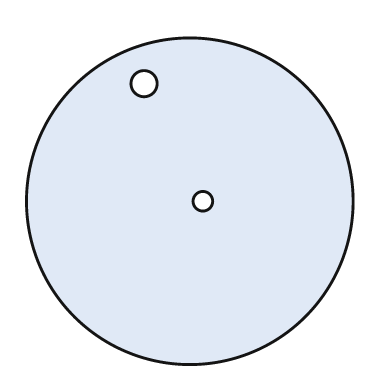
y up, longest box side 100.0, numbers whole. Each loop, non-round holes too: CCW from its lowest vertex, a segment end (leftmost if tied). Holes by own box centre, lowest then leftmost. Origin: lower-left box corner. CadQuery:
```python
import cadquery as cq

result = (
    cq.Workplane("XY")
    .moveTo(50.0, 50.0)
    .circle(50.0)
    .moveTo(54.0, 50.0)
    .circle(3.0)
    .moveTo(36.0, 86.0)
    .circle(4.0)
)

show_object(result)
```